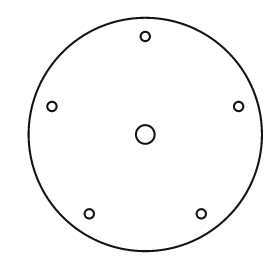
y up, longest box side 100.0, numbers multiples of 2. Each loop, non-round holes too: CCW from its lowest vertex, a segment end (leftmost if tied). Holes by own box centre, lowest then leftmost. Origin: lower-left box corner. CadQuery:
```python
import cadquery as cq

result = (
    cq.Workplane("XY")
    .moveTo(50.0, 50.0)
    .circle(50.0)
    .moveTo(26.0, 16.0)
    .circle(2.0)
    .moveTo(74.0, 16.0)
    .circle(2.0)
    .moveTo(50.0, 50.0)
    .circle(4.0)
    .moveTo(10.0, 62.0)
    .circle(2.0)
    .moveTo(90.0, 62.0)
    .circle(2.0)
    .moveTo(50.0, 92.0)
    .circle(2.0)
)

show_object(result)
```